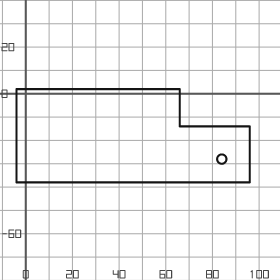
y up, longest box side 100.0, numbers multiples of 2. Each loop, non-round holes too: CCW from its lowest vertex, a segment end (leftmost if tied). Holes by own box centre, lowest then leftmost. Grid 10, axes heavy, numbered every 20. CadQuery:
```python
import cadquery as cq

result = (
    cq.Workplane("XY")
    .moveTo(-4.0, -38.0)
    .lineTo(96.0, -38.0)
    .lineTo(96.0, -14.0)
    .lineTo(66.0, -14.0)
    .lineTo(66.0, 2.0)
    .lineTo(-4.0, 2.0)
    .close()
    .moveTo(84.0, -28.0)
    .circle(2.0)
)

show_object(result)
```